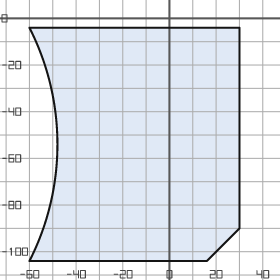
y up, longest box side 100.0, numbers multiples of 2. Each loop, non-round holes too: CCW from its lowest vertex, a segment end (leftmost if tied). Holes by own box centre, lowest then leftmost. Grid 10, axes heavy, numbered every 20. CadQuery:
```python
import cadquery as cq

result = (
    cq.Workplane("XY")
    .moveTo(-60.0, -104.0)
    .lineTo(16.0, -104.0)
    .lineTo(30.0, -90.0)
    .lineTo(30.0, -4.0)
    .lineTo(-60.0, -4.0)
    .threePointArc((-48.0, -54.0), (-60.0, -104.0))
    .close()
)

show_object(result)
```